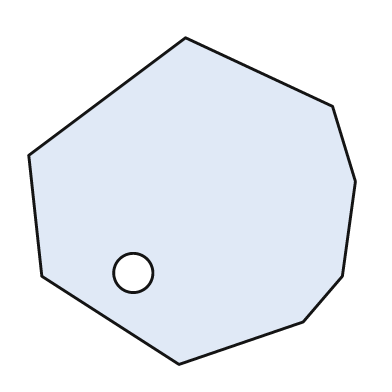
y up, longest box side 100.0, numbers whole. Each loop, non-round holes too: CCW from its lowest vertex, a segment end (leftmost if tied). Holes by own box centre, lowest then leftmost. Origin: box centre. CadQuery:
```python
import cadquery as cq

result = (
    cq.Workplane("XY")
    .moveTo(-4.0, -50.0)
    .lineTo(34.0, -37.0)
    .lineTo(46.0, -23.0)
    .lineTo(50.0, 6.0)
    .lineTo(43.0, 29.0)
    .lineTo(-2.0, 50.0)
    .lineTo(-50.0, 14.0)
    .lineTo(-46.0, -23.0)
    .close()
    .moveTo(-18.0, -22.0)
    .circle(6.0)
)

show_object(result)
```